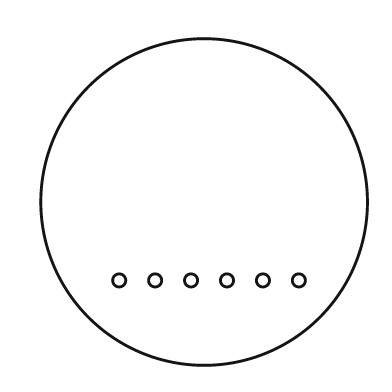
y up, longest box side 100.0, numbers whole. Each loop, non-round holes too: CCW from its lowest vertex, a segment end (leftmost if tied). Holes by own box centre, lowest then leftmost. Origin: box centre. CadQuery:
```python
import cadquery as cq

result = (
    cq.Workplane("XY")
    .moveTo(0.0, 0.0)
    .circle(50.0)
    .moveTo(-26.0, -24.0)
    .circle(2.0)
    .moveTo(-15.0, -24.0)
    .circle(2.0)
    .moveTo(-4.0, -24.0)
    .circle(2.0)
    .moveTo(7.0, -24.0)
    .circle(2.0)
    .moveTo(18.0, -24.0)
    .circle(2.0)
    .moveTo(29.0, -24.0)
    .circle(2.0)
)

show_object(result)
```